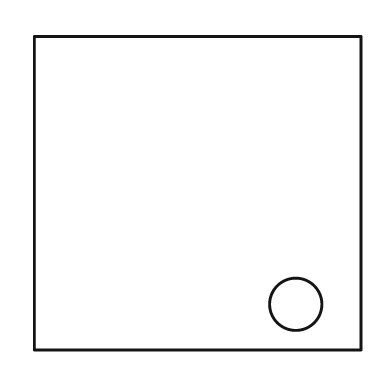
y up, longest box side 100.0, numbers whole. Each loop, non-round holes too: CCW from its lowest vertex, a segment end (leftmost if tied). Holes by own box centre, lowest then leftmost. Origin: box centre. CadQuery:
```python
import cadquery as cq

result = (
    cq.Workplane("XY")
    .moveTo(-50.0, -48.0)
    .lineTo(50.0, -48.0)
    .lineTo(50.0, 48.0)
    .lineTo(-50.0, 48.0)
    .close()
    .moveTo(30.0, -34.0)
    .circle(8.0)
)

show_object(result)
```